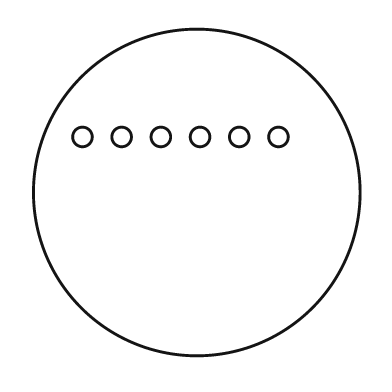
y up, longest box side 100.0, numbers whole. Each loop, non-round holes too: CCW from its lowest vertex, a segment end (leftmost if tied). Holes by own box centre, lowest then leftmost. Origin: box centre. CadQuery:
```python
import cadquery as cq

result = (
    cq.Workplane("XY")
    .moveTo(0.0, 0.0)
    .circle(50.0)
    .moveTo(-35.0, 17.0)
    .circle(3.0)
    .moveTo(-23.0, 17.0)
    .circle(3.0)
    .moveTo(-11.0, 17.0)
    .circle(3.0)
    .moveTo(1.0, 17.0)
    .circle(3.0)
    .moveTo(13.0, 17.0)
    .circle(3.0)
    .moveTo(25.0, 17.0)
    .circle(3.0)
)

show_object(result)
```